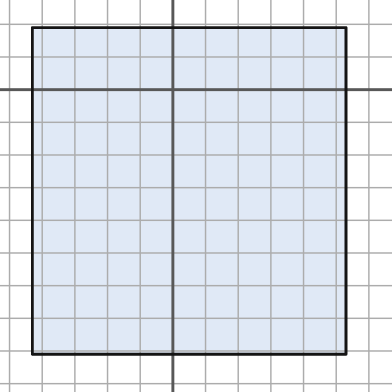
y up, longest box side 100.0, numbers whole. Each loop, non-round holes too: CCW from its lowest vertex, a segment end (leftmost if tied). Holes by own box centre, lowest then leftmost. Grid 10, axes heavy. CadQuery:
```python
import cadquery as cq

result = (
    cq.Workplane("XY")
    .moveTo(-43.0, -81.0)
    .lineTo(53.0, -81.0)
    .lineTo(53.0, 19.0)
    .lineTo(-43.0, 19.0)
    .close()
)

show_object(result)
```